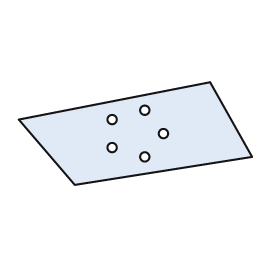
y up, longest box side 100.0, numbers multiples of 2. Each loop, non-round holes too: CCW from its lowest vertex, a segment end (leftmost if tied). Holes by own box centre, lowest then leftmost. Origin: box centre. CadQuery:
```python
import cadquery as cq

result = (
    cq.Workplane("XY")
    .moveTo(-26.0, -22.0)
    .lineTo(50.0, -10.0)
    .lineTo(32.0, 22.0)
    .lineTo(-50.0, 6.0)
    .close()
    .moveTo(4.0, -10.0)
    .circle(2.0)
    .moveTo(-10.0, -6.0)
    .circle(2.0)
    .moveTo(12.0, 0.0)
    .circle(2.0)
    .moveTo(-10.0, 6.0)
    .circle(2.0)
    .moveTo(4.0, 10.0)
    .circle(2.0)
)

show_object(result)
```